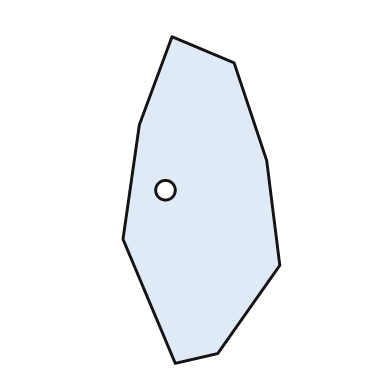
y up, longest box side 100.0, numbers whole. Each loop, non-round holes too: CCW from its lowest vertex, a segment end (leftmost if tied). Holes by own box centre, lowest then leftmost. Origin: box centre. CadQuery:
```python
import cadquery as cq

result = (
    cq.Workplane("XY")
    .moveTo(-8.0, -50.0)
    .lineTo(5.0, -47.0)
    .lineTo(24.0, -20.0)
    .lineTo(20.0, 12.0)
    .lineTo(10.0, 42.0)
    .lineTo(-9.0, 50.0)
    .lineTo(-19.0, 23.0)
    .lineTo(-24.0, -12.0)
    .close()
    .moveTo(-11.0, 3.0)
    .circle(3.0)
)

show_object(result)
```